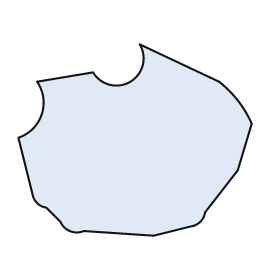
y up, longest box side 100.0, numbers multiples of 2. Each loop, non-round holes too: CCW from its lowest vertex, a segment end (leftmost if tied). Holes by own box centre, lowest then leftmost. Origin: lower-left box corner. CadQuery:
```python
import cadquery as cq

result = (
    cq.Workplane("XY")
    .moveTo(58.0, 0.0)
    .lineTo(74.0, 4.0)
    .threePointArc((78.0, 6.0), (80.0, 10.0))
    .lineTo(94.0, 28.0)
    .lineTo(100.0, 48.0)
    .threePointArc((94.0, 58.0), (86.0, 66.0))
    .lineTo(52.0, 82.0)
    .threePointArc((48.0, 66.0), (32.0, 70.0))
    .lineTo(8.0, 66.0)
    .threePointArc((10.0, 52.0), (0.0, 42.0))
    .lineTo(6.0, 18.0)
    .threePointArc((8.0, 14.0), (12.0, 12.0))
    .lineTo(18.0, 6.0)
    .threePointArc((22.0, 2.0), (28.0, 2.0))
    .close()
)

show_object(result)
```